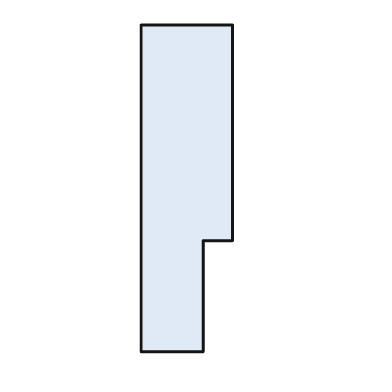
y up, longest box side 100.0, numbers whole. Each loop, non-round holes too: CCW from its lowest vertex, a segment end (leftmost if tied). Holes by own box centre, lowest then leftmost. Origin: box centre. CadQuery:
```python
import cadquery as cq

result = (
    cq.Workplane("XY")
    .moveTo(-14.0, -50.0)
    .lineTo(5.0, -50.0)
    .lineTo(5.0, -16.0)
    .lineTo(14.0, -16.0)
    .lineTo(14.0, 50.0)
    .lineTo(-14.0, 50.0)
    .close()
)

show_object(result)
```